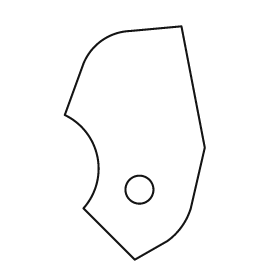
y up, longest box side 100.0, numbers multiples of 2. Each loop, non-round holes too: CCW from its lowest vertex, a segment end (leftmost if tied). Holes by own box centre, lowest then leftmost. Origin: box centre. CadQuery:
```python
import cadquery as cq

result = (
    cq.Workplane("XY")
    .moveTo(0.0, -50.0)
    .lineTo(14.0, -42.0)
    .threePointArc((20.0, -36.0), (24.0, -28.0))
    .lineTo(30.0, -2.0)
    .lineTo(20.0, 50.0)
    .lineTo(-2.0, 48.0)
    .threePointArc((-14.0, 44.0), (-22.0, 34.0))
    .lineTo(-30.0, 12.0)
    .threePointArc((-16.0, -6.0), (-22.0, -28.0))
    .close()
    .moveTo(2.0, -20.0)
    .circle(6.0)
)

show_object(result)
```